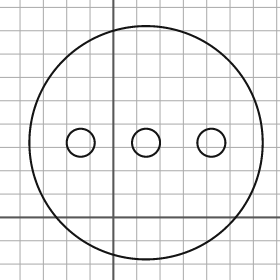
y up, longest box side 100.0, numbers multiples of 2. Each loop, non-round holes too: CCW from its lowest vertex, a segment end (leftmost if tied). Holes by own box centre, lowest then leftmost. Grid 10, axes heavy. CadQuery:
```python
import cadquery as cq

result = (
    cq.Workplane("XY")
    .moveTo(14.0, 32.0)
    .circle(50.0)
    .moveTo(-14.0, 32.0)
    .circle(6.0)
    .moveTo(14.0, 32.0)
    .circle(6.0)
    .moveTo(42.0, 32.0)
    .circle(6.0)
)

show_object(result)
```